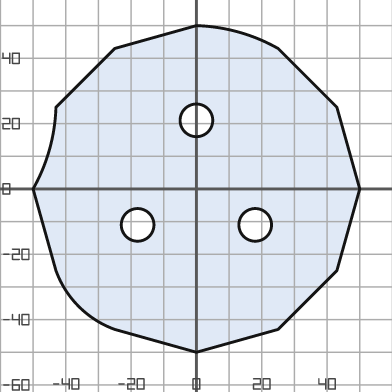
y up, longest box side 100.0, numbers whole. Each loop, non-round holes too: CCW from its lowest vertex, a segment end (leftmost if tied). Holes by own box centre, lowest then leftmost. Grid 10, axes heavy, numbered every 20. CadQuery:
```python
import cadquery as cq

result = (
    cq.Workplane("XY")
    .moveTo(0.0, -50.0)
    .lineTo(25.0, -43.0)
    .lineTo(43.0, -25.0)
    .lineTo(50.0, 0.0)
    .lineTo(43.0, 25.0)
    .lineTo(25.0, 43.0)
    .threePointArc((13.0, 48.0), (0.0, 50.0))
    .lineTo(-25.0, 43.0)
    .lineTo(-43.0, 25.0)
    .threePointArc((-45.0, 12.0), (-50.0, 0.0))
    .lineTo(-43.0, -25.0)
    .threePointArc((-36.0, -36.0), (-25.0, -43.0))
    .close()
    .moveTo(-18.0, -11.0)
    .circle(5.0)
    .moveTo(18.0, -11.0)
    .circle(5.0)
    .moveTo(0.0, 21.0)
    .circle(5.0)
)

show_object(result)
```